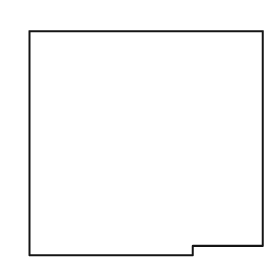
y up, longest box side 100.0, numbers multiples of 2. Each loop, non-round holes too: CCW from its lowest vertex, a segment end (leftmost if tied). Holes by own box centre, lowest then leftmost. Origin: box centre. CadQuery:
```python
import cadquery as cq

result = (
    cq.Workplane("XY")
    .moveTo(-50.0, -48.0)
    .lineTo(20.0, -48.0)
    .lineTo(20.0, -44.0)
    .lineTo(50.0, -44.0)
    .lineTo(50.0, 48.0)
    .lineTo(-50.0, 48.0)
    .close()
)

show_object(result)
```